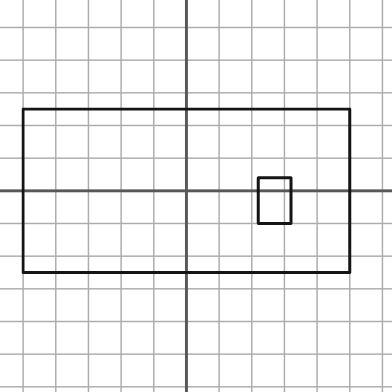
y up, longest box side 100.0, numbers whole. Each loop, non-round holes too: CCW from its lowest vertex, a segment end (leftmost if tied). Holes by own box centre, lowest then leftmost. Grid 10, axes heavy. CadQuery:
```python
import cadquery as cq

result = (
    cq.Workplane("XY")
    .moveTo(-50.0, -25.0)
    .lineTo(50.0, -25.0)
    .lineTo(50.0, 25.0)
    .lineTo(-50.0, 25.0)
    .close()
    .moveTo(22.0, -10.0)
    .lineTo(32.0, -10.0)
    .lineTo(32.0, 4.0)
    .lineTo(22.0, 4.0)
    .close()
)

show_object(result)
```